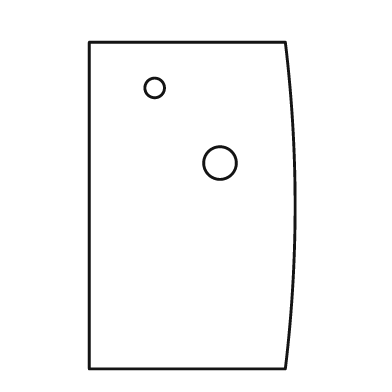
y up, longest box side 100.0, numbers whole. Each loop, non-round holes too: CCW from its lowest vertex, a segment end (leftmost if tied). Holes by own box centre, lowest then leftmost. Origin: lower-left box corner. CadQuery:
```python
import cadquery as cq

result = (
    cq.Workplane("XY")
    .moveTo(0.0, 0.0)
    .lineTo(60.0, 0.0)
    .threePointArc((63.0, 50.0), (60.0, 100.0))
    .lineTo(0.0, 100.0)
    .close()
    .moveTo(40.0, 63.0)
    .circle(5.0)
    .moveTo(20.0, 86.0)
    .circle(3.0)
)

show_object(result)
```